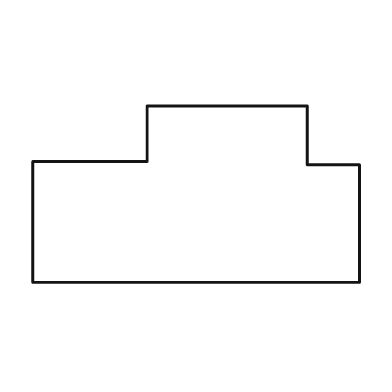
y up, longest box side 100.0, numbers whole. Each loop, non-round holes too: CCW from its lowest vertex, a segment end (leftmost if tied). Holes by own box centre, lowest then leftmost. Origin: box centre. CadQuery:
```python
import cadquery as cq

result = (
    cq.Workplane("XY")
    .moveTo(-50.0, -27.0)
    .lineTo(50.0, -27.0)
    .lineTo(50.0, 9.0)
    .lineTo(34.0, 9.0)
    .lineTo(34.0, 27.0)
    .lineTo(-15.0, 27.0)
    .lineTo(-15.0, 10.0)
    .lineTo(-50.0, 10.0)
    .close()
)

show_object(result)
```